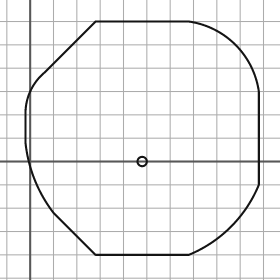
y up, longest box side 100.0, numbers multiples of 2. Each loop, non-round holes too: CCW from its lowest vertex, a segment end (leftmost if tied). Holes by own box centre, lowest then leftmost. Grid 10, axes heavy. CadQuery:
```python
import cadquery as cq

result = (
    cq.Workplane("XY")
    .moveTo(28.0, -40.0)
    .lineTo(68.0, -40.0)
    .threePointArc((86.0, -28.0), (98.0, -10.0))
    .lineTo(98.0, 30.0)
    .threePointArc((88.0, 50.0), (68.0, 60.0))
    .lineTo(28.0, 60.0)
    .lineTo(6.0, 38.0)
    .threePointArc((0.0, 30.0), (-2.0, 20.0))
    .lineTo(-2.0, 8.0)
    .threePointArc((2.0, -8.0), (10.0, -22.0))
    .close()
    .moveTo(48.0, 0.0)
    .circle(2.0)
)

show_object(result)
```